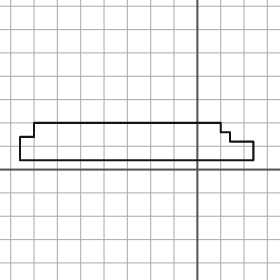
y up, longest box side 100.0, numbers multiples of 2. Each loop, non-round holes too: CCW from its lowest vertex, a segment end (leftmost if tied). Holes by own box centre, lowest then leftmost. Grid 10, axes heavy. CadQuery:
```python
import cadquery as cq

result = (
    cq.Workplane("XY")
    .moveTo(-76.0, 4.0)
    .lineTo(24.0, 4.0)
    .lineTo(24.0, 12.0)
    .lineTo(14.0, 12.0)
    .lineTo(14.0, 16.0)
    .lineTo(10.0, 16.0)
    .lineTo(10.0, 20.0)
    .lineTo(-70.0, 20.0)
    .lineTo(-70.0, 14.0)
    .lineTo(-76.0, 14.0)
    .close()
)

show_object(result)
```